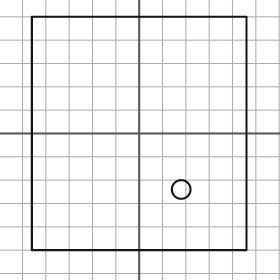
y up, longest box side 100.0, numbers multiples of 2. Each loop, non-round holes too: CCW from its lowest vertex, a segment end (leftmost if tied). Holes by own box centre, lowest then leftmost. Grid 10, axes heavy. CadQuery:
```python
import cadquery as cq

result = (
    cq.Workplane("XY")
    .moveTo(-46.0, -50.0)
    .lineTo(46.0, -50.0)
    .lineTo(46.0, 50.0)
    .lineTo(-46.0, 50.0)
    .close()
    .moveTo(18.0, -24.0)
    .circle(4.0)
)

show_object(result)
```